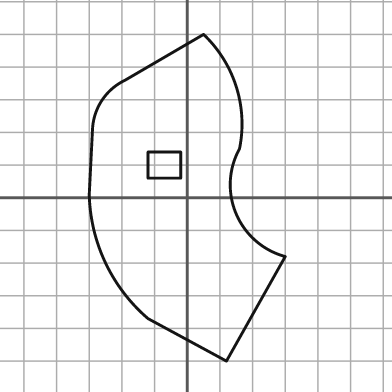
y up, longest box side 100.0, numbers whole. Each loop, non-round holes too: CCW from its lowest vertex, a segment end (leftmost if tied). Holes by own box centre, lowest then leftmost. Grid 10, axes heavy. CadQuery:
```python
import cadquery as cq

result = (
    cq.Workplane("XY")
    .moveTo(12.0, -50.0)
    .lineTo(30.0, -18.0)
    .threePointArc((15.0, -5.0), (16.0, 15.0))
    .threePointArc((15.0, 34.0), (5.0, 50.0))
    .lineTo(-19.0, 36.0)
    .threePointArc((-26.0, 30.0), (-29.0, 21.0))
    .lineTo(-30.0, 1.0)
    .threePointArc((-25.0, -20.0), (-12.0, -37.0))
    .close()
    .moveTo(-12.0, 6.0)
    .lineTo(-2.0, 6.0)
    .lineTo(-2.0, 14.0)
    .lineTo(-12.0, 14.0)
    .close()
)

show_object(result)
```